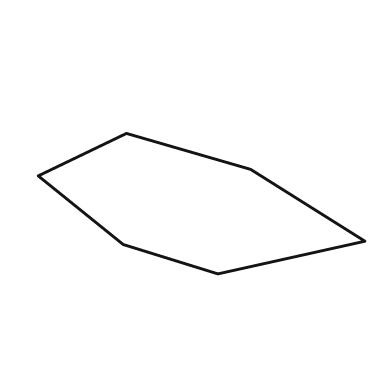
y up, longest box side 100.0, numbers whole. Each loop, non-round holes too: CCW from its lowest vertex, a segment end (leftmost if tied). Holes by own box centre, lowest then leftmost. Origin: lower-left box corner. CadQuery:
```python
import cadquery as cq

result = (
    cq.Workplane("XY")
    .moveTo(55.0, 0.0)
    .lineTo(100.0, 10.0)
    .lineTo(65.0, 32.0)
    .lineTo(27.0, 43.0)
    .lineTo(0.0, 30.0)
    .lineTo(26.0, 9.0)
    .close()
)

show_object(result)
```